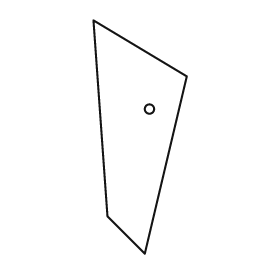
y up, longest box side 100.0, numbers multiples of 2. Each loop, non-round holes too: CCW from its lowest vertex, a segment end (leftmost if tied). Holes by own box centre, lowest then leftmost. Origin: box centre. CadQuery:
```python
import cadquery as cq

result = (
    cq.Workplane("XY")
    .moveTo(2.0, -50.0)
    .lineTo(20.0, 26.0)
    .lineTo(-20.0, 50.0)
    .lineTo(-14.0, -34.0)
    .close()
    .moveTo(4.0, 12.0)
    .circle(2.0)
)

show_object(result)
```